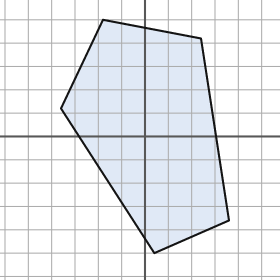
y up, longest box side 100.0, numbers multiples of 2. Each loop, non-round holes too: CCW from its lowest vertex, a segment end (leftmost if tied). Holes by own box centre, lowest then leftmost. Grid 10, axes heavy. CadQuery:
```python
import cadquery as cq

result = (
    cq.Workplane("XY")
    .moveTo(4.0, -50.0)
    .lineTo(36.0, -36.0)
    .lineTo(24.0, 42.0)
    .lineTo(-18.0, 50.0)
    .lineTo(-36.0, 12.0)
    .close()
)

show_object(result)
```